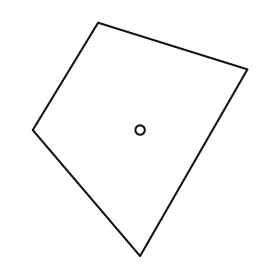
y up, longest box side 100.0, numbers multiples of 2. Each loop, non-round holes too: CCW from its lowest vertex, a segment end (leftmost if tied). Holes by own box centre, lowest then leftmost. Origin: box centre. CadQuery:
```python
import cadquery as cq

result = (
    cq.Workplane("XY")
    .moveTo(0.0, -50.0)
    .lineTo(46.0, 30.0)
    .lineTo(-18.0, 50.0)
    .lineTo(-46.0, 4.0)
    .close()
    .moveTo(0.0, 4.0)
    .circle(2.0)
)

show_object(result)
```